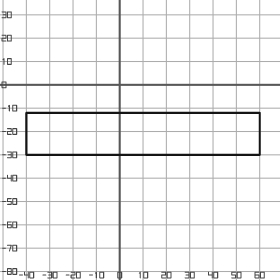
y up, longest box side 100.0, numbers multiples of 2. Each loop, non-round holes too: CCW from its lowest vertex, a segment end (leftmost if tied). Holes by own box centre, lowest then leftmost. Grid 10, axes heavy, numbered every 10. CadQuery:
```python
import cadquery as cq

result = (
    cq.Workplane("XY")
    .moveTo(-40.0, -30.0)
    .lineTo(60.0, -30.0)
    .lineTo(60.0, -12.0)
    .lineTo(-40.0, -12.0)
    .close()
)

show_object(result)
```